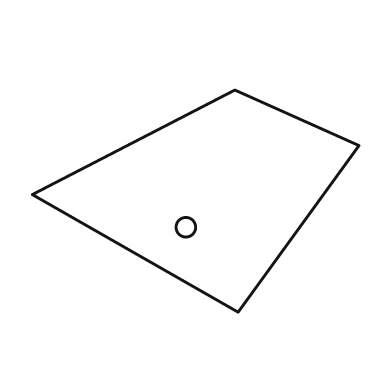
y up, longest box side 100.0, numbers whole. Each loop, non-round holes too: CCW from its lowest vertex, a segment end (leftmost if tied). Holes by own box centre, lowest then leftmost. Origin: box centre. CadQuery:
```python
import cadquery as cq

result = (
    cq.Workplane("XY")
    .moveTo(13.0, -34.0)
    .lineTo(50.0, 17.0)
    .lineTo(12.0, 34.0)
    .lineTo(-50.0, 2.0)
    .close()
    .moveTo(-3.0, -8.0)
    .circle(3.0)
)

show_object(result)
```